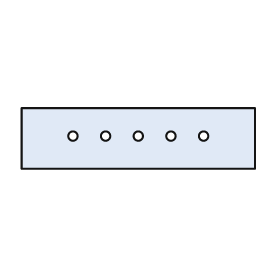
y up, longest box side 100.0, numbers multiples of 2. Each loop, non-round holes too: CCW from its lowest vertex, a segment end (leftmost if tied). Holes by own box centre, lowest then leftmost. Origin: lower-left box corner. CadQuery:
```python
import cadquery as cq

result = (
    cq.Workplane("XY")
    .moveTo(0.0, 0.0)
    .lineTo(100.0, 0.0)
    .lineTo(100.0, 26.0)
    .lineTo(0.0, 26.0)
    .close()
    .moveTo(22.0, 14.0)
    .circle(2.0)
    .moveTo(36.0, 14.0)
    .circle(2.0)
    .moveTo(50.0, 14.0)
    .circle(2.0)
    .moveTo(64.0, 14.0)
    .circle(2.0)
    .moveTo(78.0, 14.0)
    .circle(2.0)
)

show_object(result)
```